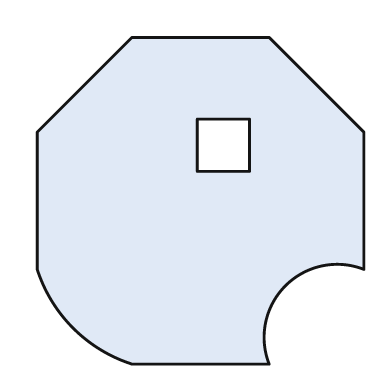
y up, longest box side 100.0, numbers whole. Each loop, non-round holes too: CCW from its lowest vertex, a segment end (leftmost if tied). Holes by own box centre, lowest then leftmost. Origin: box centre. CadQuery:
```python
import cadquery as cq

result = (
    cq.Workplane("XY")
    .moveTo(-21.0, -50.0)
    .lineTo(21.0, -50.0)
    .threePointArc((26.0, -26.0), (50.0, -21.0))
    .lineTo(50.0, 21.0)
    .lineTo(21.0, 50.0)
    .lineTo(-21.0, 50.0)
    .lineTo(-50.0, 21.0)
    .lineTo(-50.0, -21.0)
    .threePointArc((-39.0, -39.0), (-21.0, -50.0))
    .close()
    .moveTo(-1.0, 9.0)
    .lineTo(15.0, 9.0)
    .lineTo(15.0, 25.0)
    .lineTo(-1.0, 25.0)
    .close()
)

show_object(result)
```